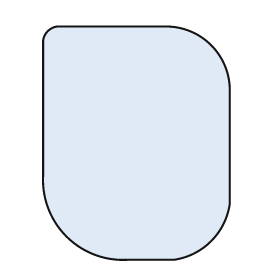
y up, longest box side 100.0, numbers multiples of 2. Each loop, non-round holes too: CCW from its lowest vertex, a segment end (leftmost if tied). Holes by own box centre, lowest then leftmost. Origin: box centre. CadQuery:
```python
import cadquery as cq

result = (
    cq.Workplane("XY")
    .moveTo(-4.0, -50.0)
    .lineTo(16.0, -50.0)
    .threePointArc((32.0, -42.0), (40.0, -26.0))
    .lineTo(40.0, 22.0)
    .threePointArc((32.0, 42.0), (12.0, 50.0))
    .lineTo(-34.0, 50.0)
    .threePointArc((-38.0, 48.0), (-40.0, 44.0))
    .lineTo(-40.0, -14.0)
    .threePointArc((-30.0, -40.0), (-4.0, -50.0))
    .close()
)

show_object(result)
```